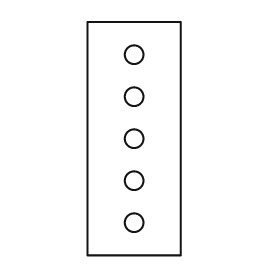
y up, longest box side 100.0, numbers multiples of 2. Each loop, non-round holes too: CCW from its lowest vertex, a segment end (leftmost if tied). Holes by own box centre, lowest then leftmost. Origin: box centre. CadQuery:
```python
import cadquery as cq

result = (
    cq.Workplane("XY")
    .moveTo(-20.0, -50.0)
    .lineTo(20.0, -50.0)
    .lineTo(20.0, 50.0)
    .lineTo(-20.0, 50.0)
    .close()
    .moveTo(0.0, -36.0)
    .circle(4.0)
    .moveTo(0.0, -18.0)
    .circle(4.0)
    .moveTo(0.0, 0.0)
    .circle(4.0)
    .moveTo(0.0, 18.0)
    .circle(4.0)
    .moveTo(0.0, 36.0)
    .circle(4.0)
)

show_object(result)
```